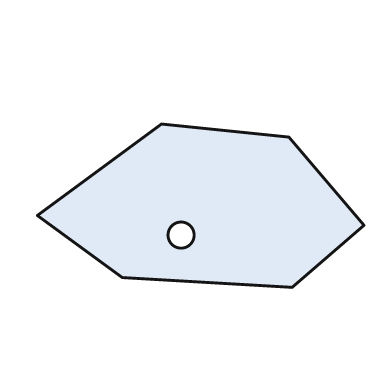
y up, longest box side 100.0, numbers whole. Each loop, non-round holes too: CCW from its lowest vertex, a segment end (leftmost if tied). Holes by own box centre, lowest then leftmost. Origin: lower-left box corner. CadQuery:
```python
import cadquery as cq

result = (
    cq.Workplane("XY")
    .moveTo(78.0, 0.0)
    .lineTo(100.0, 19.0)
    .lineTo(77.0, 46.0)
    .lineTo(38.0, 50.0)
    .lineTo(0.0, 22.0)
    .lineTo(26.0, 3.0)
    .close()
    .moveTo(44.0, 16.0)
    .circle(4.0)
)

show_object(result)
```